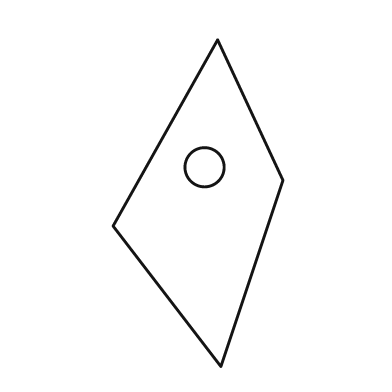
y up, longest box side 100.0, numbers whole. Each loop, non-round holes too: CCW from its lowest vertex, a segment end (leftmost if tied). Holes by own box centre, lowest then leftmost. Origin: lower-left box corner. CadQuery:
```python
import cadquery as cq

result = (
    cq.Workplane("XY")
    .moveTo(33.0, 0.0)
    .lineTo(52.0, 57.0)
    .lineTo(32.0, 100.0)
    .lineTo(0.0, 43.0)
    .close()
    .moveTo(28.0, 61.0)
    .circle(6.0)
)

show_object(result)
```